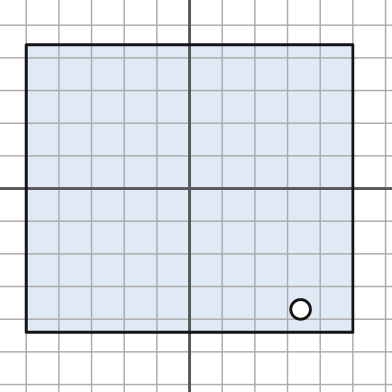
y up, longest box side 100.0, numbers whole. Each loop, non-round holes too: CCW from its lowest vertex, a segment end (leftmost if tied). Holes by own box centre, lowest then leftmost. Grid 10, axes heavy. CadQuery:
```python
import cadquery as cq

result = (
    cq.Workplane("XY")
    .moveTo(-50.0, -44.0)
    .lineTo(50.0, -44.0)
    .lineTo(50.0, 44.0)
    .lineTo(-50.0, 44.0)
    .close()
    .moveTo(34.0, -37.0)
    .circle(3.0)
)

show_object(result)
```